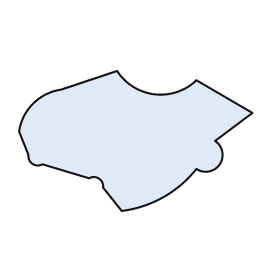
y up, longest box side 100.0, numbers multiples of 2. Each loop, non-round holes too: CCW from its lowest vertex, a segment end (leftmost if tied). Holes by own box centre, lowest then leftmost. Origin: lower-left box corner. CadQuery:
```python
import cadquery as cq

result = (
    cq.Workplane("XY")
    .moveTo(44.0, 0.0)
    .threePointArc((62.0, 6.0), (76.0, 18.0))
    .threePointArc((86.0, 20.0), (84.0, 30.0))
    .lineTo(100.0, 42.0)
    .lineTo(76.0, 56.0)
    .threePointArc((58.0, 50.0), (42.0, 60.0))
    .lineTo(18.0, 52.0)
    .threePointArc((6.0, 46.0), (0.0, 34.0))
    .lineTo(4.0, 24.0)
    .threePointArc((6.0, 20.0), (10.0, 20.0))
    .lineTo(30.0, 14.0)
    .threePointArc((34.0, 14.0), (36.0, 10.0))
    .close()
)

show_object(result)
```